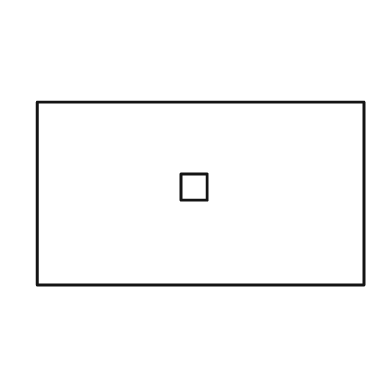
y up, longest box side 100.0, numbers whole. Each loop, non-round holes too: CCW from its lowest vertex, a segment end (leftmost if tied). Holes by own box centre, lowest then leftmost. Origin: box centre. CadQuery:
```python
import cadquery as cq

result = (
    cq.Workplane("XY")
    .moveTo(-50.0, -28.0)
    .lineTo(50.0, -28.0)
    .lineTo(50.0, 28.0)
    .lineTo(-50.0, 28.0)
    .close()
    .moveTo(-6.0, -2.0)
    .lineTo(2.0, -2.0)
    .lineTo(2.0, 6.0)
    .lineTo(-6.0, 6.0)
    .close()
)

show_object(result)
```